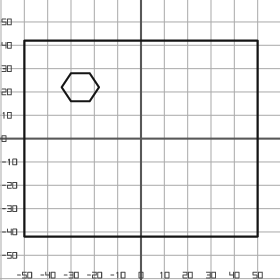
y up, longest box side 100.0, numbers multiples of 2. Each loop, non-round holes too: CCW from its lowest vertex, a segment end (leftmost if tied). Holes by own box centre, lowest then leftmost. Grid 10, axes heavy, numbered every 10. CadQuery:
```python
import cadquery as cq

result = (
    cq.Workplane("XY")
    .moveTo(-50.0, -42.0)
    .lineTo(50.0, -42.0)
    .lineTo(50.0, 42.0)
    .lineTo(-50.0, 42.0)
    .close()
    .moveTo(-30.0, 16.0)
    .lineTo(-22.0, 16.0)
    .lineTo(-18.0, 22.0)
    .lineTo(-22.0, 28.0)
    .lineTo(-30.0, 28.0)
    .lineTo(-34.0, 22.0)
    .close()
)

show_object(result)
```